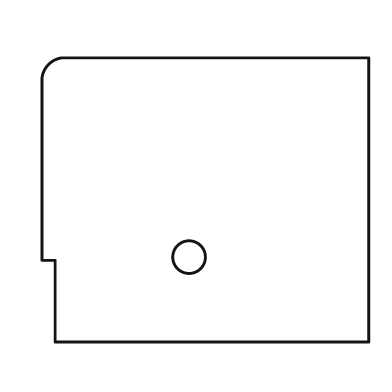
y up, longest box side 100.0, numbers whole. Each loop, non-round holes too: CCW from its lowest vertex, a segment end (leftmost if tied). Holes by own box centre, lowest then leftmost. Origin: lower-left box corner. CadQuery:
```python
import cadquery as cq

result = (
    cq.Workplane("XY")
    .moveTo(4.0, 0.0)
    .lineTo(100.0, 0.0)
    .lineTo(100.0, 87.0)
    .lineTo(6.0, 87.0)
    .threePointArc((2.0, 85.0), (0.0, 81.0))
    .lineTo(0.0, 25.0)
    .lineTo(4.0, 25.0)
    .close()
    .moveTo(45.0, 26.0)
    .circle(5.0)
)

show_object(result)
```